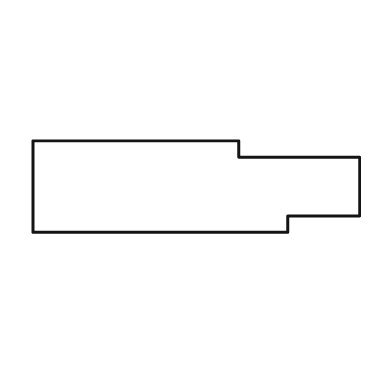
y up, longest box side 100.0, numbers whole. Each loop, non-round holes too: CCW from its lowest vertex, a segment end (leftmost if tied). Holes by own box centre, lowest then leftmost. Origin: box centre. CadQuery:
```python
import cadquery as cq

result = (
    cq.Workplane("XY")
    .moveTo(-50.0, -14.0)
    .lineTo(28.0, -14.0)
    .lineTo(28.0, -9.0)
    .lineTo(50.0, -9.0)
    .lineTo(50.0, 9.0)
    .lineTo(13.0, 9.0)
    .lineTo(13.0, 14.0)
    .lineTo(-50.0, 14.0)
    .close()
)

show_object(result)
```